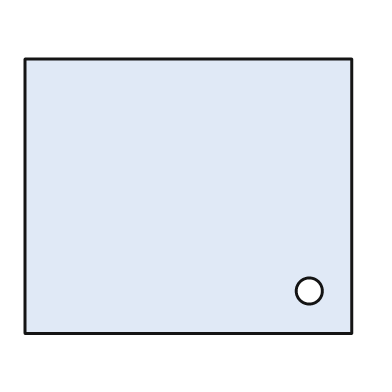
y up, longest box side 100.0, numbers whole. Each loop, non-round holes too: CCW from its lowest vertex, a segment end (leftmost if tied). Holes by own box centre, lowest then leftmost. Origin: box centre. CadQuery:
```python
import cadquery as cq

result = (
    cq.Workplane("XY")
    .moveTo(-50.0, -42.0)
    .lineTo(50.0, -42.0)
    .lineTo(50.0, 42.0)
    .lineTo(-50.0, 42.0)
    .close()
    .moveTo(37.0, -29.0)
    .circle(4.0)
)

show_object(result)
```